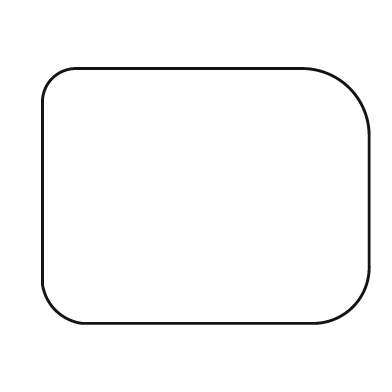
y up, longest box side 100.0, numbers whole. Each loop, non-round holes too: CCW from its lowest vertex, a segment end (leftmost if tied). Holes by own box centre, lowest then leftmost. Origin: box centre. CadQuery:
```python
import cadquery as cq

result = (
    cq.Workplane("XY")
    .moveTo(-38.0, -39.0)
    .lineTo(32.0, -39.0)
    .threePointArc((45.0, -34.0), (50.0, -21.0))
    .lineTo(50.0, 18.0)
    .threePointArc((44.0, 33.0), (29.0, 39.0))
    .lineTo(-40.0, 39.0)
    .threePointArc((-47.0, 36.0), (-50.0, 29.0))
    .lineTo(-50.0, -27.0)
    .threePointArc((-46.0, -35.0), (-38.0, -39.0))
    .close()
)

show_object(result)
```